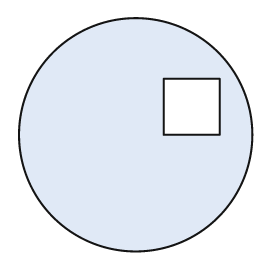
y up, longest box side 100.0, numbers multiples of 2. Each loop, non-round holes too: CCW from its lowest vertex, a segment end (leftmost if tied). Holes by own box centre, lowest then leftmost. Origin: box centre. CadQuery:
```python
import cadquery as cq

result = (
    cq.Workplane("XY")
    .moveTo(0.0, 0.0)
    .circle(50.0)
    .moveTo(12.0, 0.0)
    .lineTo(36.0, 0.0)
    .lineTo(36.0, 24.0)
    .lineTo(12.0, 24.0)
    .close()
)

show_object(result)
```